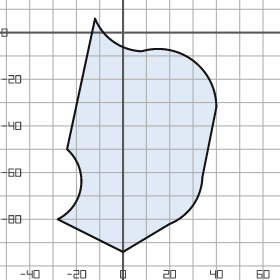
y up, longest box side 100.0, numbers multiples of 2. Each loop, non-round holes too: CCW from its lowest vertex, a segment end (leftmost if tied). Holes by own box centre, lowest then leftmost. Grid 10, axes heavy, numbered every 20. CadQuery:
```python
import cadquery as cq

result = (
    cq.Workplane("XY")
    .moveTo(0.0, -94.0)
    .lineTo(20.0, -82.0)
    .threePointArc((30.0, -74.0), (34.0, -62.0))
    .lineTo(40.0, -32.0)
    .threePointArc((30.0, -12.0), (8.0, -8.0))
    .threePointArc((-4.0, -4.0), (-12.0, 6.0))
    .lineTo(-24.0, -50.0)
    .threePointArc((-18.0, -66.0), (-28.0, -80.0))
    .close()
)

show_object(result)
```